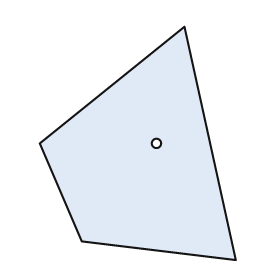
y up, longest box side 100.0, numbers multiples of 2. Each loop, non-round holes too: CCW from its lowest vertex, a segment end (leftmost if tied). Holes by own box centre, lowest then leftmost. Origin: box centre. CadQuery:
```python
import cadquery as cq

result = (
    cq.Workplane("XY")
    .moveTo(42.0, -50.0)
    .lineTo(20.0, 50.0)
    .lineTo(-42.0, 0.0)
    .lineTo(-24.0, -42.0)
    .close()
    .moveTo(8.0, 0.0)
    .circle(2.0)
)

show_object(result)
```